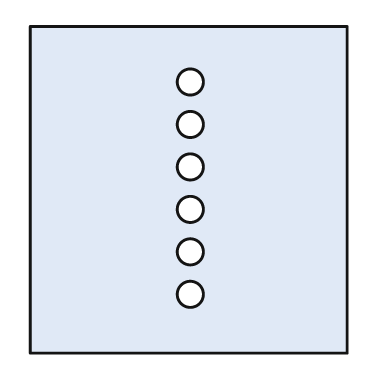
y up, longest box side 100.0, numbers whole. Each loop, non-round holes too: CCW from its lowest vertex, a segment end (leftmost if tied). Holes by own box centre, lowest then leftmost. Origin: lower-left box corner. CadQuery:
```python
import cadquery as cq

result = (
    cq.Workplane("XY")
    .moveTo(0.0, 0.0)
    .lineTo(97.0, 0.0)
    .lineTo(97.0, 100.0)
    .lineTo(0.0, 100.0)
    .close()
    .moveTo(49.0, 18.0)
    .circle(4.0)
    .moveTo(49.0, 31.0)
    .circle(4.0)
    .moveTo(49.0, 44.0)
    .circle(4.0)
    .moveTo(49.0, 57.0)
    .circle(4.0)
    .moveTo(49.0, 70.0)
    .circle(4.0)
    .moveTo(49.0, 83.0)
    .circle(4.0)
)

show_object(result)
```